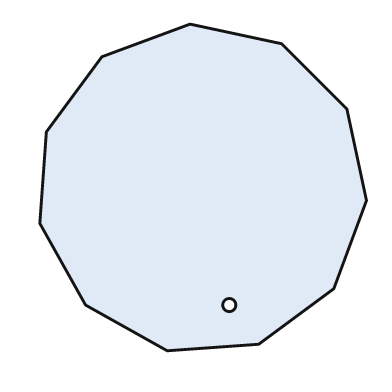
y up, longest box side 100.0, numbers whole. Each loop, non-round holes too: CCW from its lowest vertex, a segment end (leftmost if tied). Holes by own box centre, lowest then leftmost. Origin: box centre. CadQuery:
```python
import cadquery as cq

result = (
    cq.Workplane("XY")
    .moveTo(-11.0, -50.0)
    .lineTo(17.0, -48.0)
    .lineTo(40.0, -31.0)
    .lineTo(50.0, -4.0)
    .lineTo(44.0, 24.0)
    .lineTo(24.0, 44.0)
    .lineTo(-4.0, 50.0)
    .lineTo(-31.0, 40.0)
    .lineTo(-48.0, 17.0)
    .lineTo(-50.0, -11.0)
    .lineTo(-36.0, -36.0)
    .close()
    .moveTo(8.0, -36.0)
    .circle(2.0)
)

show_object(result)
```